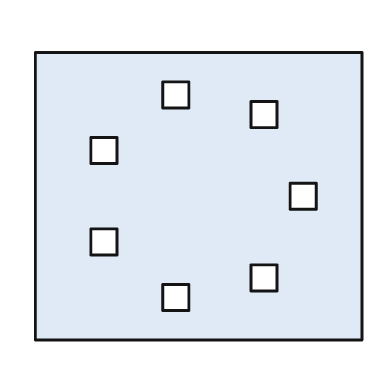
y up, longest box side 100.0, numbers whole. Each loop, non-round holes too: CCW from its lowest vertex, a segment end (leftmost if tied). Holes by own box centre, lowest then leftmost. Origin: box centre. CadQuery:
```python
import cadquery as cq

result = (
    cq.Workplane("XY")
    .moveTo(-50.0, -44.0)
    .lineTo(50.0, -44.0)
    .lineTo(50.0, 44.0)
    .lineTo(-50.0, 44.0)
    .close()
    .moveTo(-11.0, -35.0)
    .lineTo(-3.0, -35.0)
    .lineTo(-3.0, -27.0)
    .lineTo(-11.0, -27.0)
    .close()
    .moveTo(16.0, -29.0)
    .lineTo(24.0, -29.0)
    .lineTo(24.0, -21.0)
    .lineTo(16.0, -21.0)
    .close()
    .moveTo(-33.0, -18.0)
    .lineTo(-25.0, -18.0)
    .lineTo(-25.0, -10.0)
    .lineTo(-33.0, -10.0)
    .close()
    .moveTo(28.0, -4.0)
    .lineTo(36.0, -4.0)
    .lineTo(36.0, 4.0)
    .lineTo(28.0, 4.0)
    .close()
    .moveTo(-33.0, 10.0)
    .lineTo(-25.0, 10.0)
    .lineTo(-25.0, 18.0)
    .lineTo(-33.0, 18.0)
    .close()
    .moveTo(16.0, 21.0)
    .lineTo(24.0, 21.0)
    .lineTo(24.0, 29.0)
    .lineTo(16.0, 29.0)
    .close()
    .moveTo(-11.0, 27.0)
    .lineTo(-3.0, 27.0)
    .lineTo(-3.0, 35.0)
    .lineTo(-11.0, 35.0)
    .close()
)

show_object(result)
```